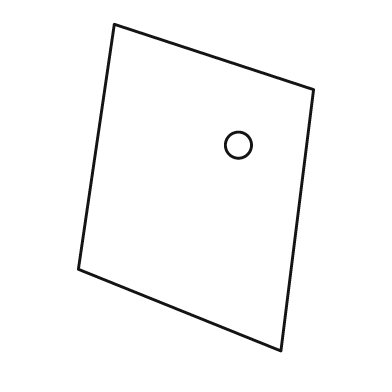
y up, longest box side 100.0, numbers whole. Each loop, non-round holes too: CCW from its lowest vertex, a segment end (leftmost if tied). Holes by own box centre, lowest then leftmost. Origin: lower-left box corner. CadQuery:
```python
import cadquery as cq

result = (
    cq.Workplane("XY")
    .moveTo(62.0, 0.0)
    .lineTo(72.0, 80.0)
    .lineTo(11.0, 100.0)
    .lineTo(0.0, 25.0)
    .close()
    .moveTo(49.0, 63.0)
    .circle(4.0)
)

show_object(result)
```